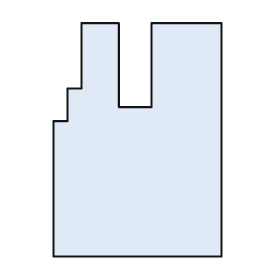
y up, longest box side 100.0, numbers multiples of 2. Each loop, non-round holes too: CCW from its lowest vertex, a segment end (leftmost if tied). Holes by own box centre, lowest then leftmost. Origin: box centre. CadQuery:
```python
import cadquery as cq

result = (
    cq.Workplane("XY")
    .moveTo(-36.0, -50.0)
    .lineTo(36.0, -50.0)
    .lineTo(36.0, 50.0)
    .lineTo(6.0, 50.0)
    .lineTo(6.0, 14.0)
    .lineTo(-8.0, 14.0)
    .lineTo(-8.0, 50.0)
    .lineTo(-24.0, 50.0)
    .lineTo(-24.0, 22.0)
    .lineTo(-30.0, 22.0)
    .lineTo(-30.0, 8.0)
    .lineTo(-36.0, 8.0)
    .close()
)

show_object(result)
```